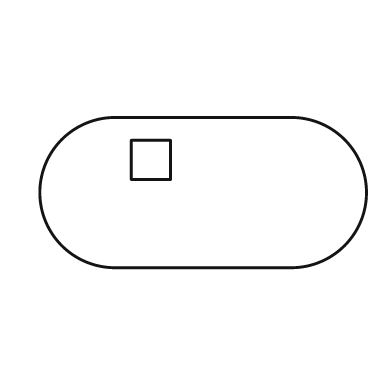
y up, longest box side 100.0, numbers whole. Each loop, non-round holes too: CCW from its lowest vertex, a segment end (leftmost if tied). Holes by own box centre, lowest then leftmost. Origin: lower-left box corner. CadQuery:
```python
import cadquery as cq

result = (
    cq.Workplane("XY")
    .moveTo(23.0, 0.0)
    .lineTo(77.0, 0.0)
    .threePointArc((100.0, 23.0), (77.0, 46.0))
    .lineTo(23.0, 46.0)
    .threePointArc((0.0, 23.0), (23.0, 0.0))
    .close()
    .moveTo(28.0, 27.0)
    .lineTo(40.0, 27.0)
    .lineTo(40.0, 39.0)
    .lineTo(28.0, 39.0)
    .close()
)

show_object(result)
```